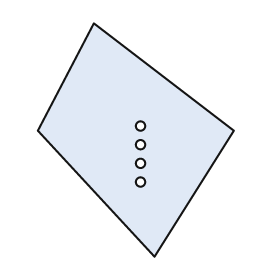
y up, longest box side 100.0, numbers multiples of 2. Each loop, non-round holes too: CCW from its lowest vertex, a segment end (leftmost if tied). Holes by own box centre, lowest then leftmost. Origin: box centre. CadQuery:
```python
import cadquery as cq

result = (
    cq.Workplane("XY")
    .moveTo(8.0, -50.0)
    .lineTo(42.0, 4.0)
    .lineTo(-18.0, 50.0)
    .lineTo(-42.0, 4.0)
    .close()
    .moveTo(2.0, -18.0)
    .circle(2.0)
    .moveTo(2.0, -10.0)
    .circle(2.0)
    .moveTo(2.0, -2.0)
    .circle(2.0)
    .moveTo(2.0, 6.0)
    .circle(2.0)
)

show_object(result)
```